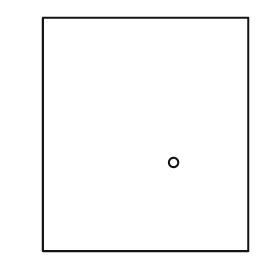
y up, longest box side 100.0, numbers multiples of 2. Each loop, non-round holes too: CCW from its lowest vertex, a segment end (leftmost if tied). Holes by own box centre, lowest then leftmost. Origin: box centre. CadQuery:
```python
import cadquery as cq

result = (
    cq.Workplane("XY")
    .moveTo(-44.0, -50.0)
    .lineTo(44.0, -50.0)
    .lineTo(44.0, 50.0)
    .lineTo(-44.0, 50.0)
    .close()
    .moveTo(12.0, -12.0)
    .circle(2.0)
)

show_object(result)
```